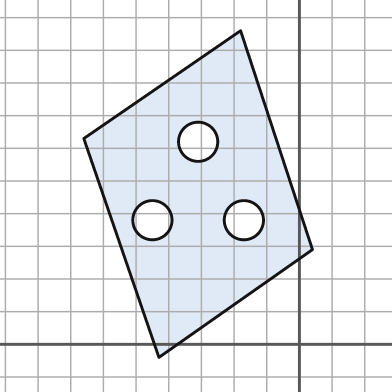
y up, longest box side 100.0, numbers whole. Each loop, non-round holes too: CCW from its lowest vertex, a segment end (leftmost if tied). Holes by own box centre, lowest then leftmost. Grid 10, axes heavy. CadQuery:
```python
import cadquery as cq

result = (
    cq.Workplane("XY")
    .moveTo(-43.0, -4.0)
    .lineTo(4.0, 29.0)
    .lineTo(-18.0, 96.0)
    .lineTo(-66.0, 63.0)
    .close()
    .moveTo(-45.0, 38.0)
    .circle(6.0)
    .moveTo(-17.0, 38.0)
    .circle(6.0)
    .moveTo(-31.0, 62.0)
    .circle(6.0)
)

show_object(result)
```